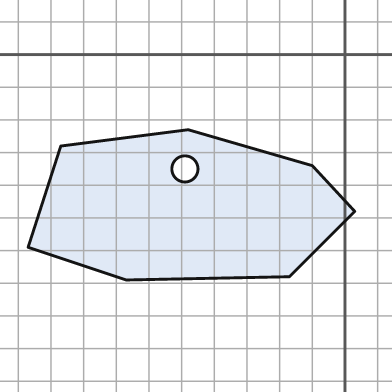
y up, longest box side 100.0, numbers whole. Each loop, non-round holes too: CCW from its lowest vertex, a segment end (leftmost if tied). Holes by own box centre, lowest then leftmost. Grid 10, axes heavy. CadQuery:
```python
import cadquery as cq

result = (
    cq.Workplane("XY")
    .moveTo(-67.0, -69.0)
    .lineTo(-17.0, -68.0)
    .lineTo(3.0, -48.0)
    .lineTo(-10.0, -34.0)
    .lineTo(-48.0, -23.0)
    .lineTo(-87.0, -28.0)
    .lineTo(-97.0, -59.0)
    .close()
    .moveTo(-49.0, -35.0)
    .circle(4.0)
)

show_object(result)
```